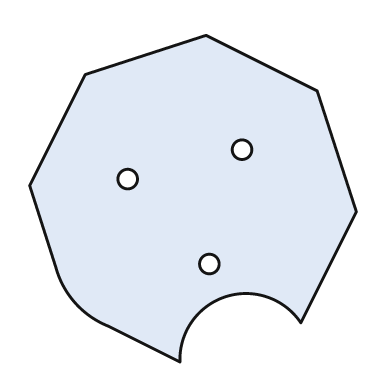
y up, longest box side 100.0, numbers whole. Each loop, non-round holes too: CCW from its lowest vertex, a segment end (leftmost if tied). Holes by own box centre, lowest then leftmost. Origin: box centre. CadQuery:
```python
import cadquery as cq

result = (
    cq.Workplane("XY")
    .moveTo(-4.0, -50.0)
    .threePointArc((10.0, -30.0), (33.0, -38.0))
    .lineTo(50.0, -4.0)
    .lineTo(38.0, 33.0)
    .lineTo(4.0, 50.0)
    .lineTo(-33.0, 38.0)
    .lineTo(-50.0, 4.0)
    .lineTo(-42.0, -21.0)
    .threePointArc((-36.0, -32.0), (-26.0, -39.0))
    .close()
    .moveTo(5.0, -20.0)
    .circle(3.0)
    .moveTo(-20.0, 6.0)
    .circle(3.0)
    .moveTo(15.0, 15.0)
    .circle(3.0)
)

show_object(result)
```